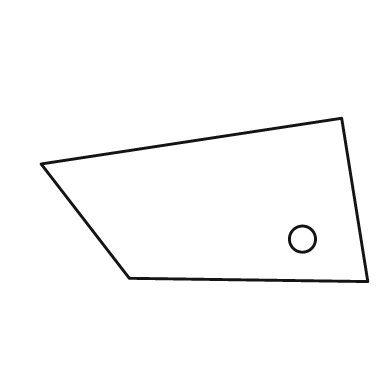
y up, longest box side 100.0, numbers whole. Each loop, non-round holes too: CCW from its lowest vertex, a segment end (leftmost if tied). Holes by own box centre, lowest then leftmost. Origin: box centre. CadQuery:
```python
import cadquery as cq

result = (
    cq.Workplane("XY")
    .moveTo(50.0, -25.0)
    .lineTo(42.0, 25.0)
    .lineTo(-50.0, 11.0)
    .lineTo(-23.0, -24.0)
    .close()
    .moveTo(30.0, -12.0)
    .circle(4.0)
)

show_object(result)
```